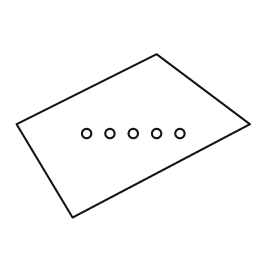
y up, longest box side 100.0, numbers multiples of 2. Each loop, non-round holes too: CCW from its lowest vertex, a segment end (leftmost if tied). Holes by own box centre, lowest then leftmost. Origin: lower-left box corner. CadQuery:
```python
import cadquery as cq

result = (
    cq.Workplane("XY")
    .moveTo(24.0, 0.0)
    .lineTo(100.0, 40.0)
    .lineTo(60.0, 70.0)
    .lineTo(0.0, 40.0)
    .close()
    .moveTo(30.0, 36.0)
    .circle(2.0)
    .moveTo(40.0, 36.0)
    .circle(2.0)
    .moveTo(50.0, 36.0)
    .circle(2.0)
    .moveTo(60.0, 36.0)
    .circle(2.0)
    .moveTo(70.0, 36.0)
    .circle(2.0)
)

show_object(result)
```